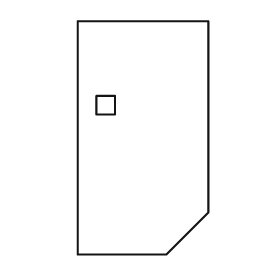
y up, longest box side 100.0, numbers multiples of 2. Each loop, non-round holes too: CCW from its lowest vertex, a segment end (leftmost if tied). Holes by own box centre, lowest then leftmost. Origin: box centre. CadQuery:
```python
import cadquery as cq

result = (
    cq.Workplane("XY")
    .moveTo(-28.0, -50.0)
    .lineTo(10.0, -50.0)
    .lineTo(28.0, -32.0)
    .lineTo(28.0, 50.0)
    .lineTo(-28.0, 50.0)
    .close()
    .moveTo(-20.0, 10.0)
    .lineTo(-12.0, 10.0)
    .lineTo(-12.0, 18.0)
    .lineTo(-20.0, 18.0)
    .close()
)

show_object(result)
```